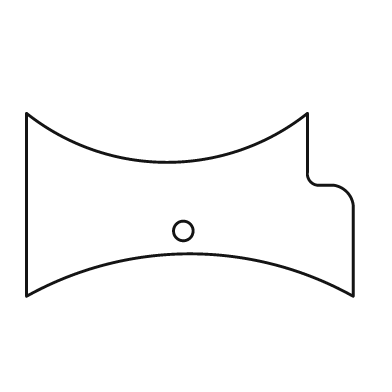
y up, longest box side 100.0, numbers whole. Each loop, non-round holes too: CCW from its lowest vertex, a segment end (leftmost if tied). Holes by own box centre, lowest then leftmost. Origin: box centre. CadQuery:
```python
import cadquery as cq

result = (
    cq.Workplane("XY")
    .moveTo(-50.0, -28.0)
    .threePointArc((0.0, -15.0), (50.0, -28.0))
    .lineTo(50.0, 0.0)
    .threePointArc((48.0, 4.0), (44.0, 6.0))
    .lineTo(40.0, 6.0)
    .threePointArc((37.0, 7.0), (36.0, 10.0))
    .lineTo(36.0, 28.0)
    .threePointArc((-7.0, 13.0), (-50.0, 28.0))
    .close()
    .moveTo(-2.0, -8.0)
    .circle(3.0)
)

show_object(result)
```